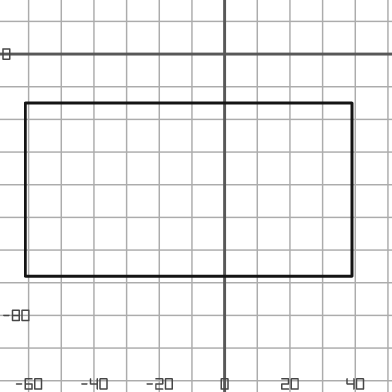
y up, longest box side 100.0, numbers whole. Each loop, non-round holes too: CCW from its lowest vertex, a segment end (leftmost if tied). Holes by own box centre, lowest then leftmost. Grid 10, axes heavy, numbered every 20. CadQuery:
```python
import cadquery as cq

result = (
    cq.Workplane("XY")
    .moveTo(-61.0, -68.0)
    .lineTo(39.0, -68.0)
    .lineTo(39.0, -15.0)
    .lineTo(-61.0, -15.0)
    .close()
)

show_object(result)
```